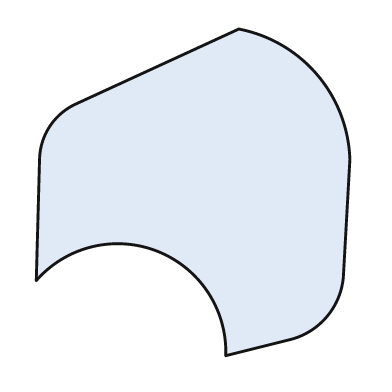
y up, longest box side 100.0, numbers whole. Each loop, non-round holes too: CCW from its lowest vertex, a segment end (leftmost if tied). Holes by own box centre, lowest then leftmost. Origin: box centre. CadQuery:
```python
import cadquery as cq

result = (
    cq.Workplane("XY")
    .moveTo(10.0, -50.0)
    .lineTo(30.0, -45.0)
    .threePointArc((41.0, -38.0), (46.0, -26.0))
    .lineTo(48.0, 10.0)
    .threePointArc((38.0, 36.0), (14.0, 50.0))
    .lineTo(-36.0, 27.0)
    .threePointArc((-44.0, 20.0), (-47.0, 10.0))
    .lineTo(-48.0, -27.0)
    .threePointArc((-11.0, -18.0), (10.0, -50.0))
    .close()
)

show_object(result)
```